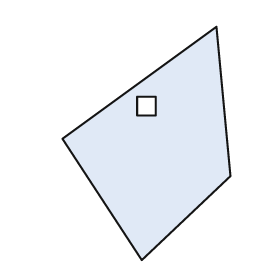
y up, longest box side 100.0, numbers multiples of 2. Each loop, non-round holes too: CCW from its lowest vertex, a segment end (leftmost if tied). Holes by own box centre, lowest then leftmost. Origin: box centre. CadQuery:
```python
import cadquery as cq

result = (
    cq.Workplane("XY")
    .moveTo(-2.0, -50.0)
    .lineTo(36.0, -14.0)
    .lineTo(30.0, 50.0)
    .lineTo(-36.0, 2.0)
    .close()
    .moveTo(-4.0, 12.0)
    .lineTo(4.0, 12.0)
    .lineTo(4.0, 20.0)
    .lineTo(-4.0, 20.0)
    .close()
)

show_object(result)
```